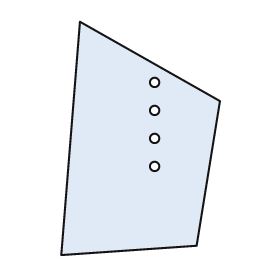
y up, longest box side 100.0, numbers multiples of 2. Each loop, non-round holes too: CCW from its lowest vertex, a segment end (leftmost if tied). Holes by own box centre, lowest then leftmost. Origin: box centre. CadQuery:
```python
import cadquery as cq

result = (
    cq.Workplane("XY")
    .moveTo(-34.0, -50.0)
    .lineTo(24.0, -46.0)
    .lineTo(34.0, 16.0)
    .lineTo(-26.0, 50.0)
    .close()
    .moveTo(6.0, -12.0)
    .circle(2.0)
    .moveTo(6.0, 0.0)
    .circle(2.0)
    .moveTo(6.0, 12.0)
    .circle(2.0)
    .moveTo(6.0, 24.0)
    .circle(2.0)
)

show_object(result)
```